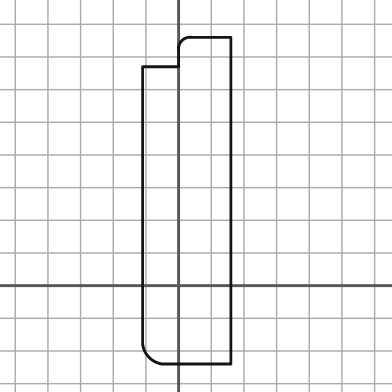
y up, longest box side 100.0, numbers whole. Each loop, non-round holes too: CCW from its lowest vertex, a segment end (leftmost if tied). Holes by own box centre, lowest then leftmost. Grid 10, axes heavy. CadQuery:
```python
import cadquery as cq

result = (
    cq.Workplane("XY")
    .moveTo(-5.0, -24.0)
    .lineTo(16.0, -24.0)
    .lineTo(16.0, 76.0)
    .lineTo(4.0, 76.0)
    .threePointArc((1.0, 75.0), (0.0, 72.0))
    .lineTo(0.0, 67.0)
    .lineTo(-11.0, 67.0)
    .lineTo(-11.0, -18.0)
    .threePointArc((-9.0, -22.0), (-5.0, -24.0))
    .close()
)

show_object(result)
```